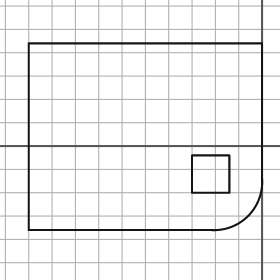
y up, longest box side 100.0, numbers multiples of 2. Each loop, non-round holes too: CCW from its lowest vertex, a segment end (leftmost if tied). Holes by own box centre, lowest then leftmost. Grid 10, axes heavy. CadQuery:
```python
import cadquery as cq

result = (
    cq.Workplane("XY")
    .moveTo(-100.0, -36.0)
    .lineTo(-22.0, -36.0)
    .threePointArc((-6.0, -30.0), (0.0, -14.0))
    .lineTo(0.0, 44.0)
    .lineTo(-100.0, 44.0)
    .close()
    .moveTo(-30.0, -20.0)
    .lineTo(-14.0, -20.0)
    .lineTo(-14.0, -4.0)
    .lineTo(-30.0, -4.0)
    .close()
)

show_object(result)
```